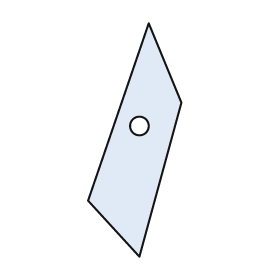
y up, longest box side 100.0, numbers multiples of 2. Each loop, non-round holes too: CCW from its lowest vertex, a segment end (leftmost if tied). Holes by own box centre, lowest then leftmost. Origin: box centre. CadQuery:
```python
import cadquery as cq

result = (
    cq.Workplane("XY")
    .moveTo(2.0, -50.0)
    .lineTo(20.0, 16.0)
    .lineTo(6.0, 50.0)
    .lineTo(-20.0, -26.0)
    .close()
    .moveTo(2.0, 6.0)
    .circle(4.0)
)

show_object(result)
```